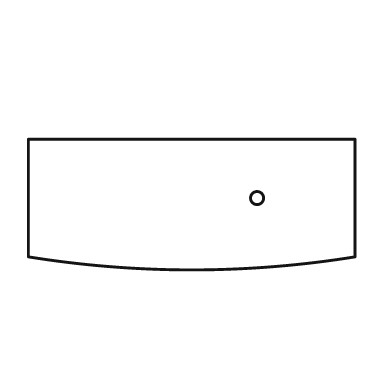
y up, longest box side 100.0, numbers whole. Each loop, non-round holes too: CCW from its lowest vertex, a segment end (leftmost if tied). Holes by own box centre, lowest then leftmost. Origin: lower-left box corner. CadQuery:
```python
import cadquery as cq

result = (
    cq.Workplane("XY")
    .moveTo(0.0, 4.0)
    .threePointArc((50.0, 0.0), (100.0, 4.0))
    .lineTo(100.0, 40.0)
    .lineTo(0.0, 40.0)
    .close()
    .moveTo(70.0, 22.0)
    .circle(2.0)
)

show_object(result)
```